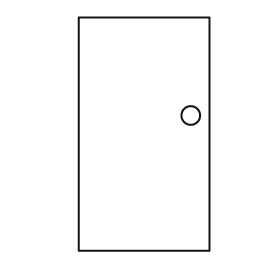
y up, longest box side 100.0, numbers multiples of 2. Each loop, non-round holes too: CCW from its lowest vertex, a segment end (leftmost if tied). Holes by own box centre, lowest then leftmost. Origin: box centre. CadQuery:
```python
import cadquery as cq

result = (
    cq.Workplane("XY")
    .moveTo(-28.0, -50.0)
    .lineTo(28.0, -50.0)
    .lineTo(28.0, 50.0)
    .lineTo(-28.0, 50.0)
    .close()
    .moveTo(20.0, 8.0)
    .circle(4.0)
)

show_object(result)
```